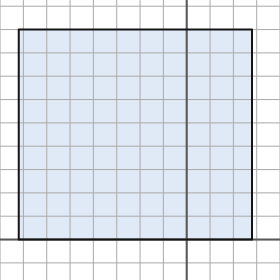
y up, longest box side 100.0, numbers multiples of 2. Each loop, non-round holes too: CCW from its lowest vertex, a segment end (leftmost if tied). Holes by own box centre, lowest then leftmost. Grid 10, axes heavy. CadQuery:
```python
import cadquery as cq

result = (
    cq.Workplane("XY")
    .moveTo(-72.0, 0.0)
    .lineTo(28.0, 0.0)
    .lineTo(28.0, 90.0)
    .lineTo(-72.0, 90.0)
    .close()
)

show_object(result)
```